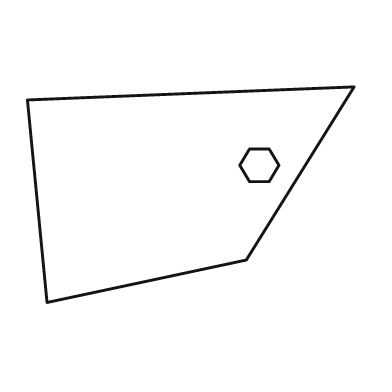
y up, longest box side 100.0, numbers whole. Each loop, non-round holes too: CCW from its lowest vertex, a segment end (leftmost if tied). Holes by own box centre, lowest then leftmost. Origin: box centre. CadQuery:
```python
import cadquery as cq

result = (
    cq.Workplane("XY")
    .moveTo(-44.0, -33.0)
    .lineTo(17.0, -20.0)
    .lineTo(50.0, 33.0)
    .lineTo(-50.0, 29.0)
    .close()
    .moveTo(18.0, 4.0)
    .lineTo(24.0, 4.0)
    .lineTo(27.0, 9.0)
    .lineTo(24.0, 14.0)
    .lineTo(18.0, 14.0)
    .lineTo(15.0, 9.0)
    .close()
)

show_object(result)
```